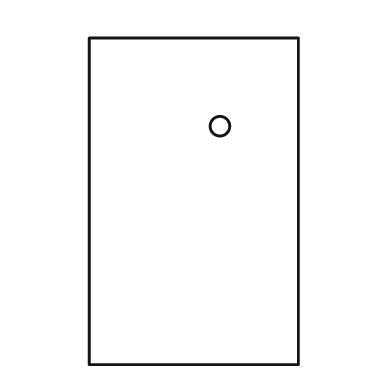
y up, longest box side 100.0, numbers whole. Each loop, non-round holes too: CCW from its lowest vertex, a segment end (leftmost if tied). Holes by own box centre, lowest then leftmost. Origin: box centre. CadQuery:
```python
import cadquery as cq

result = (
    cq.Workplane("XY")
    .moveTo(-32.0, -50.0)
    .lineTo(32.0, -50.0)
    .lineTo(32.0, 50.0)
    .lineTo(-32.0, 50.0)
    .close()
    .moveTo(8.0, 23.0)
    .circle(3.0)
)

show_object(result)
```